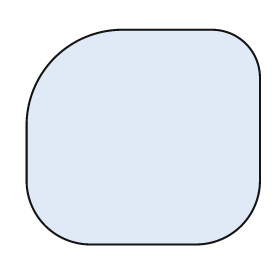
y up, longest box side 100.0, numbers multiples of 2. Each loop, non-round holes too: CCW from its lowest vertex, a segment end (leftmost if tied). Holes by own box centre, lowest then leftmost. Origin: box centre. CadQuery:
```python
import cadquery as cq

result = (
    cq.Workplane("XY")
    .moveTo(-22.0, -46.0)
    .lineTo(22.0, -46.0)
    .threePointArc((42.0, -38.0), (50.0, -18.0))
    .lineTo(50.0, 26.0)
    .threePointArc((44.0, 40.0), (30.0, 46.0))
    .lineTo(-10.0, 46.0)
    .threePointArc((-38.0, 34.0), (-50.0, 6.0))
    .lineTo(-50.0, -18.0)
    .threePointArc((-42.0, -38.0), (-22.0, -46.0))
    .close()
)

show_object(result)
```